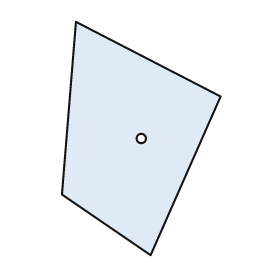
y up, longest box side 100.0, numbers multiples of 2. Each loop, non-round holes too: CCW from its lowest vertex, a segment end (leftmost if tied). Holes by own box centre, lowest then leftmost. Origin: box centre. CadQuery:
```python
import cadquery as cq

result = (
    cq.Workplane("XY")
    .moveTo(4.0, -50.0)
    .lineTo(34.0, 18.0)
    .lineTo(-28.0, 50.0)
    .lineTo(-34.0, -24.0)
    .close()
    .moveTo(0.0, 0.0)
    .circle(2.0)
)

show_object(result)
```